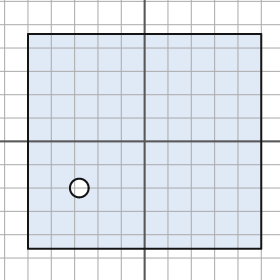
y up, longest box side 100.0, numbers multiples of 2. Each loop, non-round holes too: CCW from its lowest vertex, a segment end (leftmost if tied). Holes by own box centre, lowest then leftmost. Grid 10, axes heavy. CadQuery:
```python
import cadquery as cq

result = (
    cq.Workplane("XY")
    .moveTo(-50.0, -46.0)
    .lineTo(50.0, -46.0)
    .lineTo(50.0, 46.0)
    .lineTo(-50.0, 46.0)
    .close()
    .moveTo(-28.0, -20.0)
    .circle(4.0)
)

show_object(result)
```